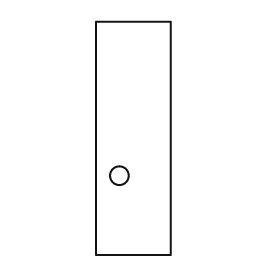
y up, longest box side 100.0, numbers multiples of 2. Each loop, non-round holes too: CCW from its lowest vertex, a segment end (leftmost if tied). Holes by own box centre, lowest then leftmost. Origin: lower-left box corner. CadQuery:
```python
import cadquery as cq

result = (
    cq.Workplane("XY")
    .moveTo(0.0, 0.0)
    .lineTo(32.0, 0.0)
    .lineTo(32.0, 100.0)
    .lineTo(0.0, 100.0)
    .close()
    .moveTo(10.0, 34.0)
    .circle(4.0)
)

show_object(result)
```